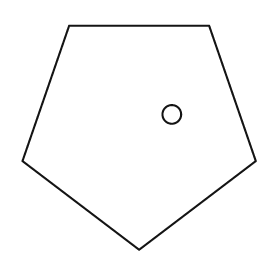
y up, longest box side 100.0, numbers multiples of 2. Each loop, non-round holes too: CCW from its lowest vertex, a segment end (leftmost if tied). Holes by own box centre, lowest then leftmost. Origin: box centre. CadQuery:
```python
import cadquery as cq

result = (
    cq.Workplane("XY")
    .moveTo(0.0, -48.0)
    .lineTo(50.0, -10.0)
    .lineTo(30.0, 48.0)
    .lineTo(-30.0, 48.0)
    .lineTo(-50.0, -10.0)
    .close()
    .moveTo(14.0, 10.0)
    .circle(4.0)
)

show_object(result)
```